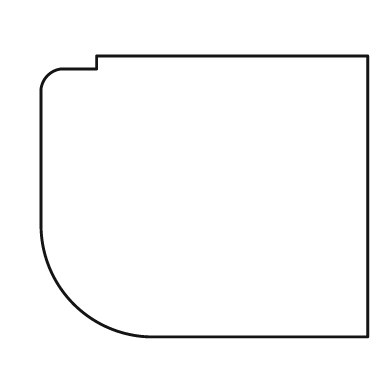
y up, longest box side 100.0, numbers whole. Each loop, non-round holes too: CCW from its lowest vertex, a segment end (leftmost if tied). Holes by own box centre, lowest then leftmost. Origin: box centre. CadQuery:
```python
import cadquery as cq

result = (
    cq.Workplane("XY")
    .moveTo(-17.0, -43.0)
    .lineTo(50.0, -43.0)
    .lineTo(50.0, 43.0)
    .lineTo(-33.0, 43.0)
    .lineTo(-33.0, 39.0)
    .lineTo(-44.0, 39.0)
    .threePointArc((-48.0, 37.0), (-50.0, 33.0))
    .lineTo(-50.0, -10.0)
    .threePointArc((-40.0, -33.0), (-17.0, -43.0))
    .close()
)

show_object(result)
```